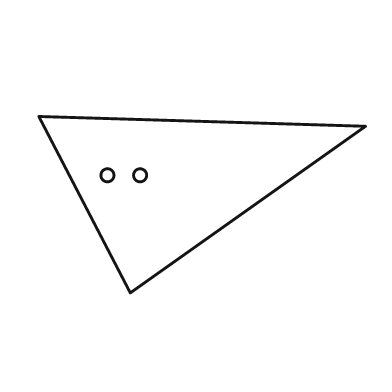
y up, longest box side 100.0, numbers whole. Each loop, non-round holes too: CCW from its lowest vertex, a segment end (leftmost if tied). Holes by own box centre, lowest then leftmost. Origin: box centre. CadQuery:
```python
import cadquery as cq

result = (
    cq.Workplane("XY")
    .moveTo(-22.0, -27.0)
    .lineTo(50.0, 24.0)
    .lineTo(-50.0, 27.0)
    .close()
    .moveTo(-29.0, 9.0)
    .circle(2.0)
    .moveTo(-19.0, 9.0)
    .circle(2.0)
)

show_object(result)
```